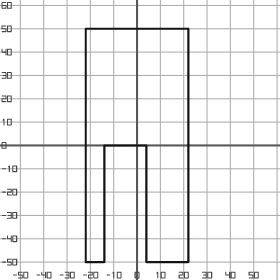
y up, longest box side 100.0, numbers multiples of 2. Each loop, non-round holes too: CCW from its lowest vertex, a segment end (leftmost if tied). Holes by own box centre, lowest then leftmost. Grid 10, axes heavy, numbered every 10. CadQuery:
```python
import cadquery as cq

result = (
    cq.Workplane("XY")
    .moveTo(-22.0, -50.0)
    .lineTo(-14.0, -50.0)
    .lineTo(-14.0, 0.0)
    .lineTo(4.0, 0.0)
    .lineTo(4.0, -50.0)
    .lineTo(22.0, -50.0)
    .lineTo(22.0, 50.0)
    .lineTo(-22.0, 50.0)
    .close()
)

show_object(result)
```